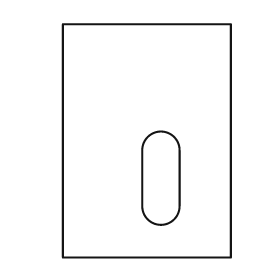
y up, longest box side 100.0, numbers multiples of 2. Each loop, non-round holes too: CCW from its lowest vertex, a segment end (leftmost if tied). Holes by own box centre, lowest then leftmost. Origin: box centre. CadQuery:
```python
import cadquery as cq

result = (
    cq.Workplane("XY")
    .moveTo(-36.0, -50.0)
    .lineTo(36.0, -50.0)
    .lineTo(36.0, 50.0)
    .lineTo(-36.0, 50.0)
    .close()
    .moveTo(-2.0, -28.0)
    .threePointArc((6.0, -36.0), (14.0, -28.0))
    .lineTo(14.0, -4.0)
    .threePointArc((6.0, 4.0), (-2.0, -4.0))
    .close()
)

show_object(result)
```